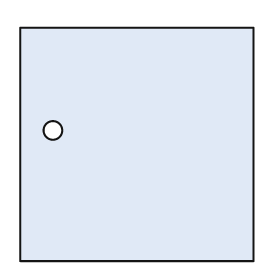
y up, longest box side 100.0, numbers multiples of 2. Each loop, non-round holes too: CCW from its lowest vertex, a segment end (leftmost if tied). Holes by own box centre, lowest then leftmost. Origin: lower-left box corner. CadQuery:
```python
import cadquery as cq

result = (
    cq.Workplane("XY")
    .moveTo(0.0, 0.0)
    .lineTo(100.0, 0.0)
    .lineTo(100.0, 100.0)
    .lineTo(0.0, 100.0)
    .close()
    .moveTo(14.0, 56.0)
    .circle(4.0)
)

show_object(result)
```